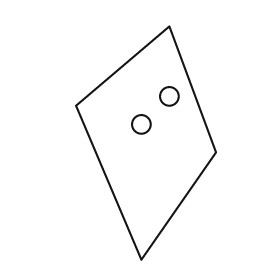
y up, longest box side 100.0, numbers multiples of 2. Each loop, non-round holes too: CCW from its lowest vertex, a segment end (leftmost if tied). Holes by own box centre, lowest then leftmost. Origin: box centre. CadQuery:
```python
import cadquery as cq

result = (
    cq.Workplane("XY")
    .moveTo(-2.0, -50.0)
    .lineTo(30.0, -4.0)
    .lineTo(10.0, 50.0)
    .lineTo(-30.0, 16.0)
    .close()
    .moveTo(-2.0, 8.0)
    .circle(4.0)
    .moveTo(10.0, 20.0)
    .circle(4.0)
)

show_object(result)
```